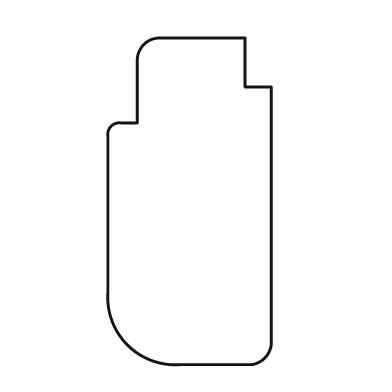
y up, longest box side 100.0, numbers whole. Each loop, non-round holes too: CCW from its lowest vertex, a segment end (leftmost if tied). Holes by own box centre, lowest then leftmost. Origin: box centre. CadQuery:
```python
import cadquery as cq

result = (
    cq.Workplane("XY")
    .moveTo(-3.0, -50.0)
    .lineTo(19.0, -50.0)
    .threePointArc((23.0, -48.0), (25.0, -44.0))
    .lineTo(25.0, 35.0)
    .lineTo(17.0, 35.0)
    .lineTo(17.0, 50.0)
    .lineTo(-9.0, 50.0)
    .threePointArc((-14.0, 48.0), (-16.0, 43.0))
    .lineTo(-16.0, 24.0)
    .lineTo(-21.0, 24.0)
    .threePointArc((-24.0, 23.0), (-25.0, 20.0))
    .lineTo(-25.0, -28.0)
    .threePointArc((-19.0, -44.0), (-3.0, -50.0))
    .close()
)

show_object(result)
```